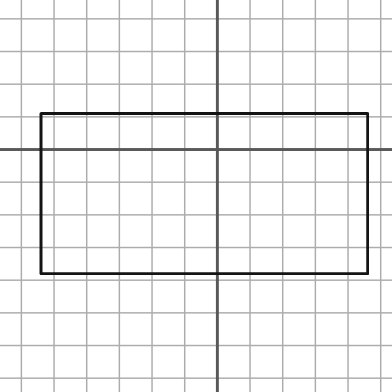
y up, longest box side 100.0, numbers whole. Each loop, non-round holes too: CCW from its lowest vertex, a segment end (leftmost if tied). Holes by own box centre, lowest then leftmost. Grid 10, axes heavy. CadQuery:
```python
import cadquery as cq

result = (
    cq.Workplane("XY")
    .moveTo(-54.0, -38.0)
    .lineTo(46.0, -38.0)
    .lineTo(46.0, 11.0)
    .lineTo(-54.0, 11.0)
    .close()
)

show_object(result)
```